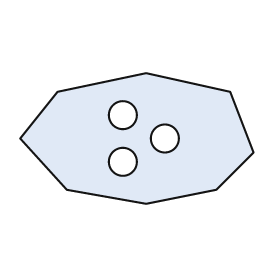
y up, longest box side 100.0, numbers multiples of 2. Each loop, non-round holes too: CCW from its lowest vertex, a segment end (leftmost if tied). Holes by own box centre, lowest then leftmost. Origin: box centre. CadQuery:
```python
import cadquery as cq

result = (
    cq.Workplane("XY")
    .moveTo(4.0, -28.0)
    .lineTo(34.0, -22.0)
    .lineTo(50.0, -6.0)
    .lineTo(40.0, 20.0)
    .lineTo(4.0, 28.0)
    .lineTo(-34.0, 20.0)
    .lineTo(-50.0, 0.0)
    .lineTo(-30.0, -22.0)
    .close()
    .moveTo(-6.0, -10.0)
    .circle(6.0)
    .moveTo(12.0, 0.0)
    .circle(6.0)
    .moveTo(-6.0, 10.0)
    .circle(6.0)
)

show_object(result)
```